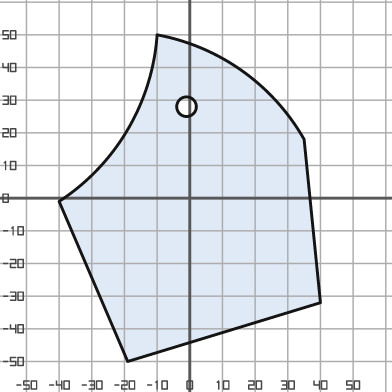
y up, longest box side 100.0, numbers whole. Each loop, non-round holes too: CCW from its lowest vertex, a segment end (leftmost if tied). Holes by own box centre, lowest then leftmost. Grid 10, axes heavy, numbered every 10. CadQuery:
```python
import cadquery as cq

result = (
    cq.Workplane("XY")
    .moveTo(-19.0, -50.0)
    .lineTo(40.0, -32.0)
    .lineTo(35.0, 18.0)
    .threePointArc((16.0, 39.0), (-10.0, 50.0))
    .threePointArc((-19.0, 21.0), (-40.0, -1.0))
    .close()
    .moveTo(-1.0, 28.0)
    .circle(3.0)
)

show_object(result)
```